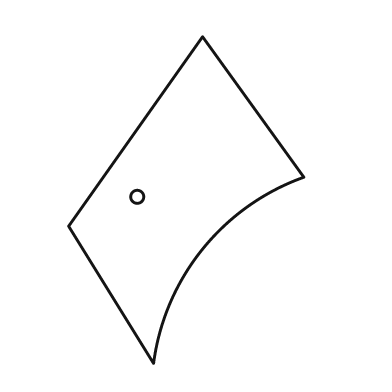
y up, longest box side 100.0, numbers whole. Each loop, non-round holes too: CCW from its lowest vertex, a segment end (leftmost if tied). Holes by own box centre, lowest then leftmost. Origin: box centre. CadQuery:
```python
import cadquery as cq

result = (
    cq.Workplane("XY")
    .moveTo(-10.0, -50.0)
    .threePointArc((5.0, -15.0), (36.0, 7.0))
    .lineTo(5.0, 50.0)
    .lineTo(-36.0, -8.0)
    .close()
    .moveTo(-15.0, 1.0)
    .circle(2.0)
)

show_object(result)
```